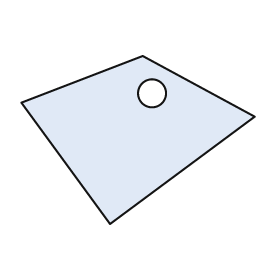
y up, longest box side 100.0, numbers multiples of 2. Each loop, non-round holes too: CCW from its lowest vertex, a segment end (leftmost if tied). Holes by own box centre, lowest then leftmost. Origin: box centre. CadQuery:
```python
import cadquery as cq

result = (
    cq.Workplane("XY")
    .moveTo(-12.0, -36.0)
    .lineTo(50.0, 10.0)
    .lineTo(2.0, 36.0)
    .lineTo(-50.0, 16.0)
    .close()
    .moveTo(6.0, 20.0)
    .circle(6.0)
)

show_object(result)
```